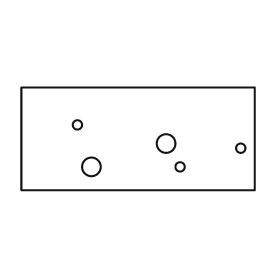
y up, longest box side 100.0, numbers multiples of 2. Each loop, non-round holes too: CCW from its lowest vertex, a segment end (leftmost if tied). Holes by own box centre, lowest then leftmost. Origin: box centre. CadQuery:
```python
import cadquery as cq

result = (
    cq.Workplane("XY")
    .moveTo(-50.0, -22.0)
    .lineTo(50.0, -22.0)
    .lineTo(50.0, 22.0)
    .lineTo(-50.0, 22.0)
    .close()
    .moveTo(-20.0, -12.0)
    .circle(4.0)
    .moveTo(18.0, -12.0)
    .circle(2.0)
    .moveTo(44.0, -4.0)
    .circle(2.0)
    .moveTo(12.0, -2.0)
    .circle(4.0)
    .moveTo(-26.0, 6.0)
    .circle(2.0)
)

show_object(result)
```